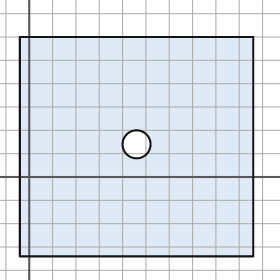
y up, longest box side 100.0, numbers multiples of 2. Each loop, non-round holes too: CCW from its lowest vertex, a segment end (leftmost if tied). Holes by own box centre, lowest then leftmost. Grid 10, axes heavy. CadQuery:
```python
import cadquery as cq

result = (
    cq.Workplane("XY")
    .moveTo(-4.0, -34.0)
    .lineTo(96.0, -34.0)
    .lineTo(96.0, 60.0)
    .lineTo(-4.0, 60.0)
    .close()
    .moveTo(46.0, 14.0)
    .circle(6.0)
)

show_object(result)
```